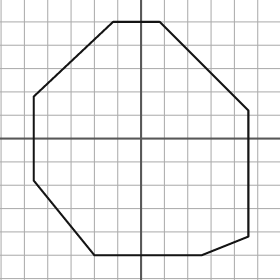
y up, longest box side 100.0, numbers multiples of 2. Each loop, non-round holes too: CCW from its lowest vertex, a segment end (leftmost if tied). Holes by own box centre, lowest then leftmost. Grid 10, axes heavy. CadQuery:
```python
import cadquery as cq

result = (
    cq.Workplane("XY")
    .moveTo(-20.0, -50.0)
    .lineTo(26.0, -50.0)
    .lineTo(46.0, -42.0)
    .lineTo(46.0, 12.0)
    .lineTo(8.0, 50.0)
    .lineTo(-12.0, 50.0)
    .lineTo(-46.0, 18.0)
    .lineTo(-46.0, -18.0)
    .close()
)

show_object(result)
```